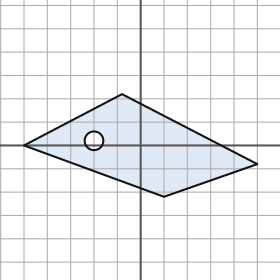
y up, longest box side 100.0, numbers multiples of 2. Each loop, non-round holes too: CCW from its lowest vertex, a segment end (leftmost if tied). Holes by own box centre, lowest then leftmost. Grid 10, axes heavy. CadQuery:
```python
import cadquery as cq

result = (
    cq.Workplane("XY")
    .moveTo(10.0, -22.0)
    .lineTo(50.0, -8.0)
    .lineTo(-8.0, 22.0)
    .lineTo(-50.0, 0.0)
    .close()
    .moveTo(-20.0, 2.0)
    .circle(4.0)
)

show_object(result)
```